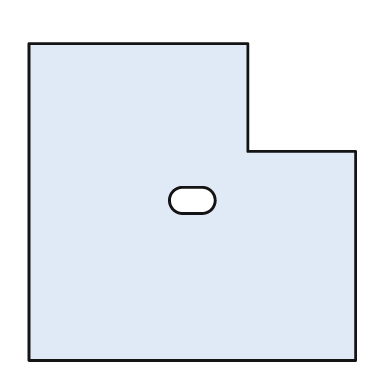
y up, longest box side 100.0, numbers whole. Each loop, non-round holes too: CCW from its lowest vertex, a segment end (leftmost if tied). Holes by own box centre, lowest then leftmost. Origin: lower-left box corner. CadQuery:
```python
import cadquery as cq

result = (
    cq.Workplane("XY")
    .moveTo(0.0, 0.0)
    .lineTo(100.0, 0.0)
    .lineTo(100.0, 64.0)
    .lineTo(67.0, 64.0)
    .lineTo(67.0, 97.0)
    .lineTo(0.0, 97.0)
    .close()
    .moveTo(47.0, 45.0)
    .lineTo(53.0, 45.0)
    .threePointArc((57.0, 49.0), (53.0, 53.0))
    .lineTo(47.0, 53.0)
    .threePointArc((43.0, 49.0), (47.0, 45.0))
    .close()
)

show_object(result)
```